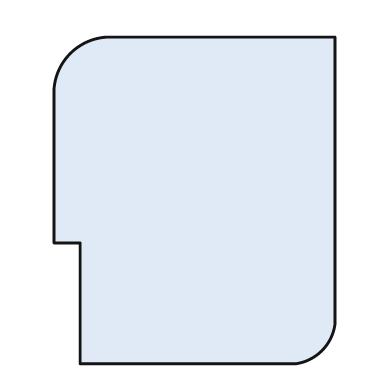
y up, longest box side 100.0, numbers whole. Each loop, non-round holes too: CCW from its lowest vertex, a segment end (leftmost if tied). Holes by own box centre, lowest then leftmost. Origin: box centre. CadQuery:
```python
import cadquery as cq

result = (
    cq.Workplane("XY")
    .moveTo(-35.0, -50.0)
    .lineTo(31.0, -50.0)
    .threePointArc((39.0, -46.0), (43.0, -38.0))
    .lineTo(43.0, 50.0)
    .lineTo(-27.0, 50.0)
    .threePointArc((-38.0, 45.0), (-43.0, 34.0))
    .lineTo(-43.0, -13.0)
    .lineTo(-35.0, -13.0)
    .close()
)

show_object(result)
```